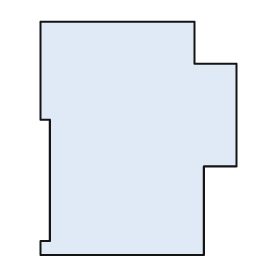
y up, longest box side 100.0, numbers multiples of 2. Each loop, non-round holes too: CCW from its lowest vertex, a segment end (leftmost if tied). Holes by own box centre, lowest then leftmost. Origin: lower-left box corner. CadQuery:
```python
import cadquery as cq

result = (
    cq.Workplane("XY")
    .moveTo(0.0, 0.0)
    .lineTo(70.0, 0.0)
    .lineTo(70.0, 38.0)
    .lineTo(84.0, 38.0)
    .lineTo(84.0, 82.0)
    .lineTo(66.0, 82.0)
    .lineTo(66.0, 100.0)
    .lineTo(0.0, 100.0)
    .lineTo(0.0, 58.0)
    .lineTo(4.0, 58.0)
    .lineTo(4.0, 6.0)
    .lineTo(0.0, 6.0)
    .close()
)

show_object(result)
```